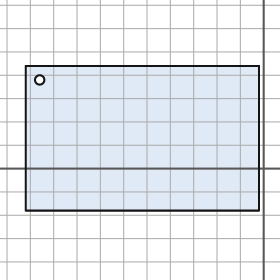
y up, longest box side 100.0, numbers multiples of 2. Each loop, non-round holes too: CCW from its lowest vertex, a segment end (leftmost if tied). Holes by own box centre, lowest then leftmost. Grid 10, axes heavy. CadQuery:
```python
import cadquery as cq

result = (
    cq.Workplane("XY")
    .moveTo(-102.0, -18.0)
    .lineTo(-2.0, -18.0)
    .lineTo(-2.0, 44.0)
    .lineTo(-102.0, 44.0)
    .close()
    .moveTo(-96.0, 38.0)
    .circle(2.0)
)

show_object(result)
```